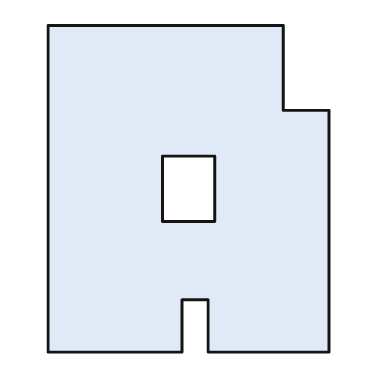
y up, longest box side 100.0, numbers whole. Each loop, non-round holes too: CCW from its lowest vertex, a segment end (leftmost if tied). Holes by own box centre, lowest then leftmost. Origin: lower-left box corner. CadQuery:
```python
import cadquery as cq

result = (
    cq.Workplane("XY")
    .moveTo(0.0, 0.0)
    .lineTo(41.0, 0.0)
    .lineTo(41.0, 16.0)
    .lineTo(49.0, 16.0)
    .lineTo(49.0, 0.0)
    .lineTo(86.0, 0.0)
    .lineTo(86.0, 74.0)
    .lineTo(72.0, 74.0)
    .lineTo(72.0, 100.0)
    .lineTo(0.0, 100.0)
    .close()
    .moveTo(35.0, 40.0)
    .lineTo(51.0, 40.0)
    .lineTo(51.0, 60.0)
    .lineTo(35.0, 60.0)
    .close()
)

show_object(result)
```